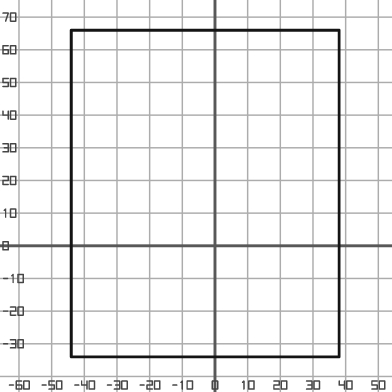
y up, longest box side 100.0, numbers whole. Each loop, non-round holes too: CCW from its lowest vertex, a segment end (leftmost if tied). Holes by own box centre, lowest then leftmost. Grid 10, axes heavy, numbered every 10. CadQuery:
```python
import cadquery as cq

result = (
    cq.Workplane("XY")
    .moveTo(-44.0, -34.0)
    .lineTo(38.0, -34.0)
    .lineTo(38.0, 66.0)
    .lineTo(-44.0, 66.0)
    .close()
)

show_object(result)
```